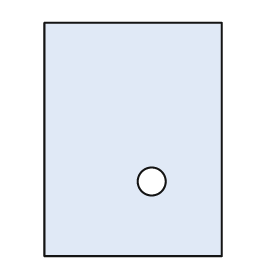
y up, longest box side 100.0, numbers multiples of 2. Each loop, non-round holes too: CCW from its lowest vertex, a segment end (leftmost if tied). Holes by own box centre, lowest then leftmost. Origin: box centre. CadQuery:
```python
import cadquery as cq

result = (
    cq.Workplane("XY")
    .moveTo(-38.0, -50.0)
    .lineTo(38.0, -50.0)
    .lineTo(38.0, 50.0)
    .lineTo(-38.0, 50.0)
    .close()
    .moveTo(8.0, -18.0)
    .circle(6.0)
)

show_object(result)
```